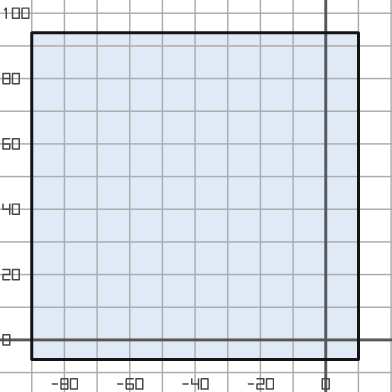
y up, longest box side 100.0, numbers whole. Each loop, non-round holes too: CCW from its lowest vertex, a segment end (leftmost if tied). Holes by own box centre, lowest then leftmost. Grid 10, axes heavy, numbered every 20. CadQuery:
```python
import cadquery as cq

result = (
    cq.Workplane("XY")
    .moveTo(-90.0, -6.0)
    .lineTo(10.0, -6.0)
    .lineTo(10.0, 94.0)
    .lineTo(-90.0, 94.0)
    .close()
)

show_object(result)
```